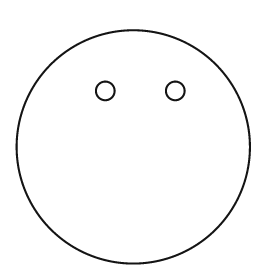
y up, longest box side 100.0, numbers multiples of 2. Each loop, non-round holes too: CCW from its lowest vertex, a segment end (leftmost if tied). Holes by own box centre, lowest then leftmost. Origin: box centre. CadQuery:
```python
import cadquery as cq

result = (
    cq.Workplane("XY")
    .moveTo(0.0, 0.0)
    .circle(50.0)
    .moveTo(-12.0, 24.0)
    .circle(4.0)
    .moveTo(18.0, 24.0)
    .circle(4.0)
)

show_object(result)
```